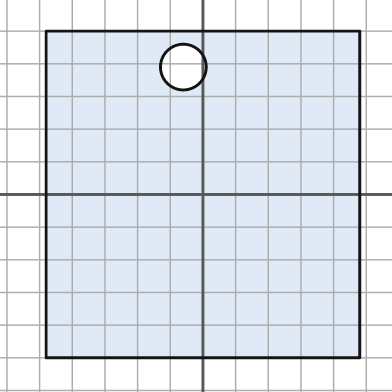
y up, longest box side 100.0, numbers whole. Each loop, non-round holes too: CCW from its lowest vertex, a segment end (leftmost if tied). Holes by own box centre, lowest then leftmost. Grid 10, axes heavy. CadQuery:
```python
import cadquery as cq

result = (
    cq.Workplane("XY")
    .moveTo(-48.0, -50.0)
    .lineTo(48.0, -50.0)
    .lineTo(48.0, 50.0)
    .lineTo(-48.0, 50.0)
    .close()
    .moveTo(-6.0, 39.0)
    .circle(7.0)
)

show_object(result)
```